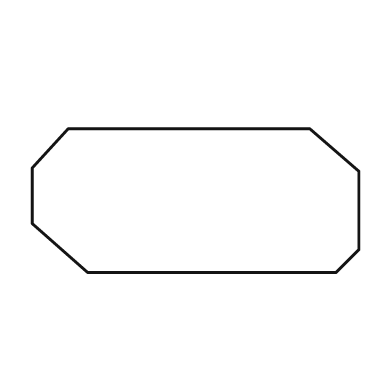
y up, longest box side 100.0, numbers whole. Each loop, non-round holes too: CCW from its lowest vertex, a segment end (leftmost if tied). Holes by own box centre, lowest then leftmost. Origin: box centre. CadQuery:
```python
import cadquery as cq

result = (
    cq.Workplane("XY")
    .moveTo(-33.0, -22.0)
    .lineTo(43.0, -22.0)
    .lineTo(50.0, -15.0)
    .lineTo(50.0, 9.0)
    .lineTo(35.0, 22.0)
    .lineTo(-39.0, 22.0)
    .lineTo(-50.0, 10.0)
    .lineTo(-50.0, -7.0)
    .close()
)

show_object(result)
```